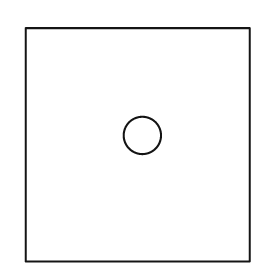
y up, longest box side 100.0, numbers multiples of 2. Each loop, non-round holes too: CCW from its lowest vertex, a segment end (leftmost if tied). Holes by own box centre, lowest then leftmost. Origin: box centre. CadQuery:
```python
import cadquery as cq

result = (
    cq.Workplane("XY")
    .moveTo(-48.0, -50.0)
    .lineTo(48.0, -50.0)
    .lineTo(48.0, 50.0)
    .lineTo(-48.0, 50.0)
    .close()
    .moveTo(2.0, 4.0)
    .circle(8.0)
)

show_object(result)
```